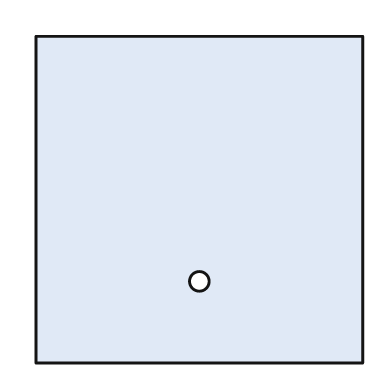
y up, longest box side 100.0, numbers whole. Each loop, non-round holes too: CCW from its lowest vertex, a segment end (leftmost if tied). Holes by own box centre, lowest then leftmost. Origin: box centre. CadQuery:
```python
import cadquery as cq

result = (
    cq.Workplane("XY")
    .moveTo(-50.0, -50.0)
    .lineTo(50.0, -50.0)
    .lineTo(50.0, 50.0)
    .lineTo(-50.0, 50.0)
    .close()
    .moveTo(0.0, -25.0)
    .circle(3.0)
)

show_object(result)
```